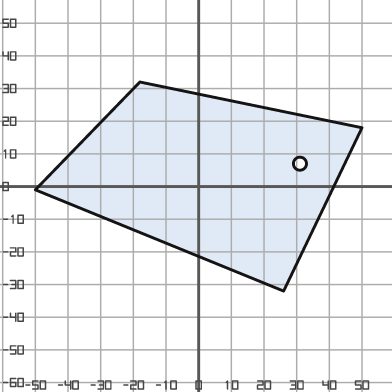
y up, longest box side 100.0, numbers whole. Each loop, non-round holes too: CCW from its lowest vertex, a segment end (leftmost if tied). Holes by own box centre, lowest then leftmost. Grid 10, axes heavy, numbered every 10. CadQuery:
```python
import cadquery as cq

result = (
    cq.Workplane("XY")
    .moveTo(26.0, -32.0)
    .lineTo(50.0, 18.0)
    .lineTo(-18.0, 32.0)
    .lineTo(-50.0, -1.0)
    .close()
    .moveTo(31.0, 7.0)
    .circle(2.0)
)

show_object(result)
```